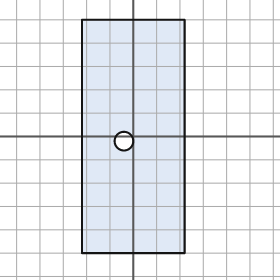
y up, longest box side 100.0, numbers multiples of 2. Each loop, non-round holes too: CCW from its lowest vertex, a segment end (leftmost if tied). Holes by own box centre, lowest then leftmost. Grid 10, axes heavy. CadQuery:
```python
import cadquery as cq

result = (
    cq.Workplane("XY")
    .moveTo(-22.0, -50.0)
    .lineTo(22.0, -50.0)
    .lineTo(22.0, 50.0)
    .lineTo(-22.0, 50.0)
    .close()
    .moveTo(-4.0, -2.0)
    .circle(4.0)
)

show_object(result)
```